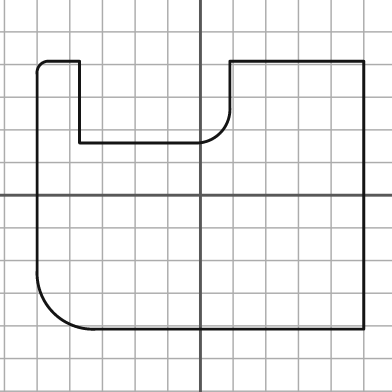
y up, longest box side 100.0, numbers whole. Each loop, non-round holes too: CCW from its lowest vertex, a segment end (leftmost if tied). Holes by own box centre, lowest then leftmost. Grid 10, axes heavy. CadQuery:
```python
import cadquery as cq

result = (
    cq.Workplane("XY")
    .moveTo(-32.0, -41.0)
    .lineTo(50.0, -41.0)
    .lineTo(50.0, 41.0)
    .lineTo(9.0, 41.0)
    .lineTo(9.0, 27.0)
    .threePointArc((6.0, 19.0), (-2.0, 16.0))
    .lineTo(-37.0, 16.0)
    .lineTo(-37.0, 41.0)
    .lineTo(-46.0, 41.0)
    .threePointArc((-49.0, 40.0), (-50.0, 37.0))
    .lineTo(-50.0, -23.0)
    .threePointArc((-45.0, -36.0), (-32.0, -41.0))
    .close()
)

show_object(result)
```